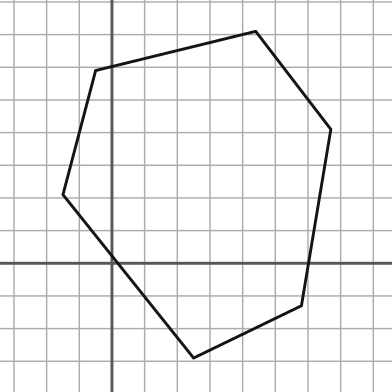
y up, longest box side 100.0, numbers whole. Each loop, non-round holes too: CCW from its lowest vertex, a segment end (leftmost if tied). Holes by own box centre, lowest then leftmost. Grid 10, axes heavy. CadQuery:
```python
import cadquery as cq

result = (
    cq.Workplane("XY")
    .moveTo(25.0, -29.0)
    .lineTo(58.0, -13.0)
    .lineTo(67.0, 41.0)
    .lineTo(44.0, 71.0)
    .lineTo(-5.0, 59.0)
    .lineTo(-15.0, 21.0)
    .close()
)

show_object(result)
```